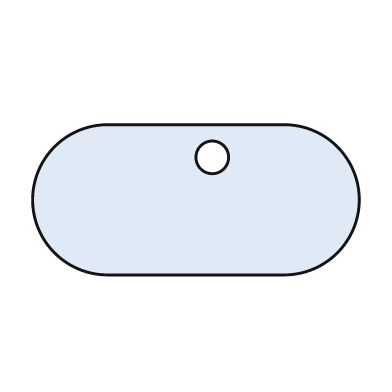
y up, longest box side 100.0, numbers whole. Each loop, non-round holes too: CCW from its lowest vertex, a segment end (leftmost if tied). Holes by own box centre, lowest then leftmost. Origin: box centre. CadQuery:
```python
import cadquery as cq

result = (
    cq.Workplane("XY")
    .moveTo(-27.0, -23.0)
    .lineTo(27.0, -23.0)
    .threePointArc((50.0, 0.0), (27.0, 23.0))
    .lineTo(-27.0, 23.0)
    .threePointArc((-50.0, 0.0), (-27.0, -23.0))
    .close()
    .moveTo(5.0, 13.0)
    .circle(5.0)
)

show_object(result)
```